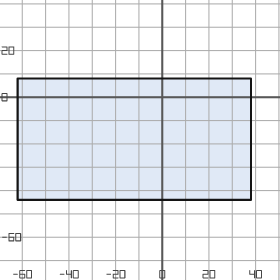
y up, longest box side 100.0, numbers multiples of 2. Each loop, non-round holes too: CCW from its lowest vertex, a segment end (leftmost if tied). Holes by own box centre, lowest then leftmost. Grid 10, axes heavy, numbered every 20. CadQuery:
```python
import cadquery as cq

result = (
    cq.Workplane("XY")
    .moveTo(-62.0, -44.0)
    .lineTo(38.0, -44.0)
    .lineTo(38.0, 8.0)
    .lineTo(-62.0, 8.0)
    .close()
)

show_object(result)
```